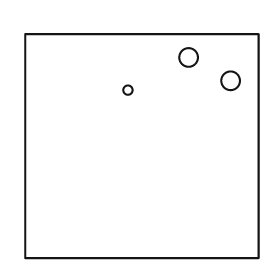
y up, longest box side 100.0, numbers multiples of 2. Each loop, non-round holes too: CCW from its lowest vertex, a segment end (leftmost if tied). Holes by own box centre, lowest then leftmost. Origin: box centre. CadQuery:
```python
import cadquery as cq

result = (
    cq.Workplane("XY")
    .moveTo(-50.0, -48.0)
    .lineTo(50.0, -48.0)
    .lineTo(50.0, 48.0)
    .lineTo(-50.0, 48.0)
    .close()
    .moveTo(-6.0, 24.0)
    .circle(2.0)
    .moveTo(38.0, 28.0)
    .circle(4.0)
    .moveTo(20.0, 38.0)
    .circle(4.0)
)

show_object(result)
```